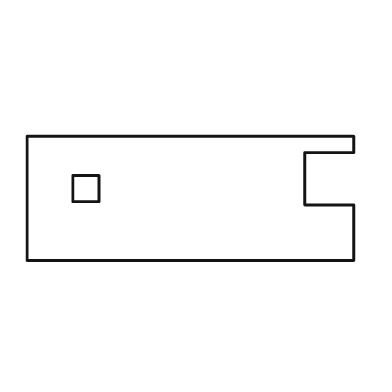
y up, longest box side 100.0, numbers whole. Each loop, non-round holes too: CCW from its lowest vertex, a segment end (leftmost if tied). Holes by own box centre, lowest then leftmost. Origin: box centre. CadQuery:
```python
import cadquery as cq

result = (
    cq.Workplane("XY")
    .moveTo(-50.0, -19.0)
    .lineTo(50.0, -19.0)
    .lineTo(50.0, -2.0)
    .lineTo(35.0, -2.0)
    .lineTo(35.0, 14.0)
    .lineTo(50.0, 14.0)
    .lineTo(50.0, 19.0)
    .lineTo(-50.0, 19.0)
    .close()
    .moveTo(-36.0, -1.0)
    .lineTo(-28.0, -1.0)
    .lineTo(-28.0, 7.0)
    .lineTo(-36.0, 7.0)
    .close()
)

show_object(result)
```